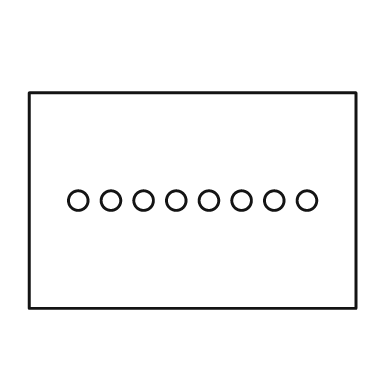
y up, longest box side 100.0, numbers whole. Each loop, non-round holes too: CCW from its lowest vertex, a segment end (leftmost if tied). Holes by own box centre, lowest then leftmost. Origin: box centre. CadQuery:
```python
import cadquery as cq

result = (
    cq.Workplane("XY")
    .moveTo(-50.0, -33.0)
    .lineTo(50.0, -33.0)
    .lineTo(50.0, 33.0)
    .lineTo(-50.0, 33.0)
    .close()
    .moveTo(-35.0, 0.0)
    .circle(3.0)
    .moveTo(-25.0, 0.0)
    .circle(3.0)
    .moveTo(-15.0, 0.0)
    .circle(3.0)
    .moveTo(-5.0, 0.0)
    .circle(3.0)
    .moveTo(5.0, 0.0)
    .circle(3.0)
    .moveTo(15.0, 0.0)
    .circle(3.0)
    .moveTo(25.0, 0.0)
    .circle(3.0)
    .moveTo(35.0, 0.0)
    .circle(3.0)
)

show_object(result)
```